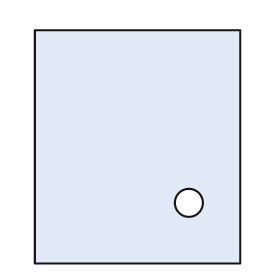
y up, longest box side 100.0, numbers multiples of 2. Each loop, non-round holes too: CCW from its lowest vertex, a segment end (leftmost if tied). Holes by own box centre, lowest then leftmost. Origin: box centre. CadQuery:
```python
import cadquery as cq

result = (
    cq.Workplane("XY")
    .moveTo(-44.0, -50.0)
    .lineTo(44.0, -50.0)
    .lineTo(44.0, 50.0)
    .lineTo(-44.0, 50.0)
    .close()
    .moveTo(22.0, -24.0)
    .circle(6.0)
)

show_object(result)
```